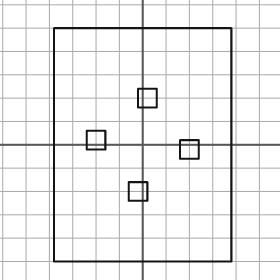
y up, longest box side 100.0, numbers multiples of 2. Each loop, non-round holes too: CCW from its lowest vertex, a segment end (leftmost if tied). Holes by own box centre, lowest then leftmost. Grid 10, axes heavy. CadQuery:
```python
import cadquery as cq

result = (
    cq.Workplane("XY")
    .moveTo(-38.0, -50.0)
    .lineTo(38.0, -50.0)
    .lineTo(38.0, 50.0)
    .lineTo(-38.0, 50.0)
    .close()
    .moveTo(-6.0, -24.0)
    .lineTo(2.0, -24.0)
    .lineTo(2.0, -16.0)
    .lineTo(-6.0, -16.0)
    .close()
    .moveTo(16.0, -6.0)
    .lineTo(24.0, -6.0)
    .lineTo(24.0, 2.0)
    .lineTo(16.0, 2.0)
    .close()
    .moveTo(-24.0, -2.0)
    .lineTo(-16.0, -2.0)
    .lineTo(-16.0, 6.0)
    .lineTo(-24.0, 6.0)
    .close()
    .moveTo(-2.0, 16.0)
    .lineTo(6.0, 16.0)
    .lineTo(6.0, 24.0)
    .lineTo(-2.0, 24.0)
    .close()
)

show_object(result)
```